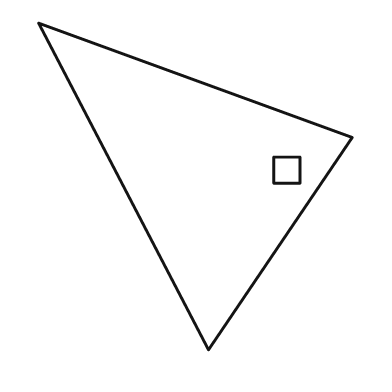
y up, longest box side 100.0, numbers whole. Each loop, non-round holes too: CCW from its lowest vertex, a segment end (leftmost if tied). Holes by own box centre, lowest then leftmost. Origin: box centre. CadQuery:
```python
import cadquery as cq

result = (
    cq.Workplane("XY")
    .moveTo(4.0, -50.0)
    .lineTo(48.0, 15.0)
    .lineTo(-48.0, 50.0)
    .close()
    .moveTo(24.0, 1.0)
    .lineTo(32.0, 1.0)
    .lineTo(32.0, 9.0)
    .lineTo(24.0, 9.0)
    .close()
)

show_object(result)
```